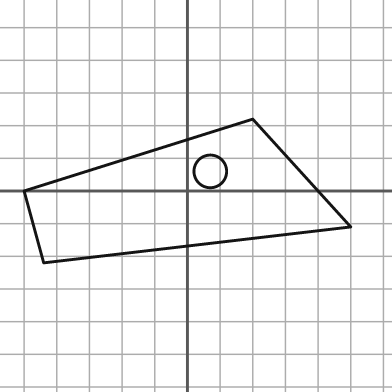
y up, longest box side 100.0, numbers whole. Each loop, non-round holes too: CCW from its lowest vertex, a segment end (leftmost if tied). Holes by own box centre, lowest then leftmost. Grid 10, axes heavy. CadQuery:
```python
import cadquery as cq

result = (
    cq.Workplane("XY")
    .moveTo(-44.0, -22.0)
    .lineTo(50.0, -11.0)
    .lineTo(20.0, 22.0)
    .lineTo(-50.0, 0.0)
    .close()
    .moveTo(7.0, 6.0)
    .circle(5.0)
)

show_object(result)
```